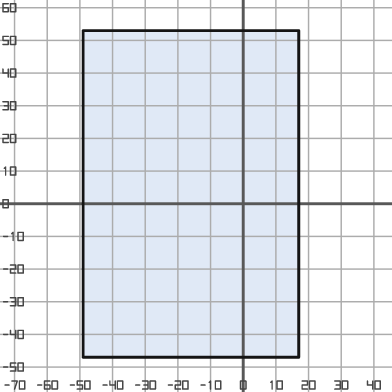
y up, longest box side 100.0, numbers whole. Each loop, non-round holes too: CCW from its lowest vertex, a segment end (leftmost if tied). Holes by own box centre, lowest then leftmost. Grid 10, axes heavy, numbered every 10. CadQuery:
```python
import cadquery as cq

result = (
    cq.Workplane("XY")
    .moveTo(-49.0, -47.0)
    .lineTo(17.0, -47.0)
    .lineTo(17.0, 53.0)
    .lineTo(-49.0, 53.0)
    .close()
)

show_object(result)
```